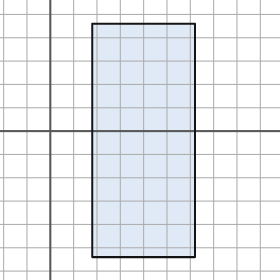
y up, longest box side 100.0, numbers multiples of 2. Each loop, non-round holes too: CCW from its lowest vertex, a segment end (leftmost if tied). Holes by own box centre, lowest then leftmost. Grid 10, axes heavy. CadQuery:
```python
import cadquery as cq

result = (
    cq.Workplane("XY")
    .moveTo(18.0, -54.0)
    .lineTo(62.0, -54.0)
    .lineTo(62.0, 46.0)
    .lineTo(18.0, 46.0)
    .close()
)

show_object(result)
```